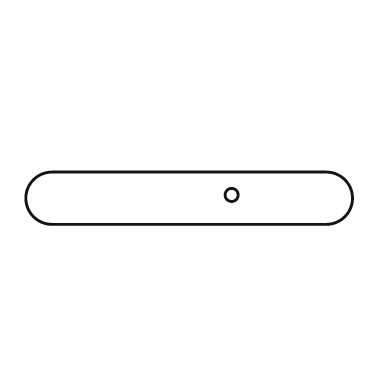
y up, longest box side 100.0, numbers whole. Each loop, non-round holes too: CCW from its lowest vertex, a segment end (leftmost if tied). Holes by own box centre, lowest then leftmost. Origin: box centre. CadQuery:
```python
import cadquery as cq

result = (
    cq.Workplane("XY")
    .moveTo(-42.0, -8.0)
    .lineTo(42.0, -8.0)
    .threePointArc((50.0, 0.0), (42.0, 8.0))
    .lineTo(-42.0, 8.0)
    .threePointArc((-50.0, 0.0), (-42.0, -8.0))
    .close()
    .moveTo(13.0, 1.0)
    .circle(2.0)
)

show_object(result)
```